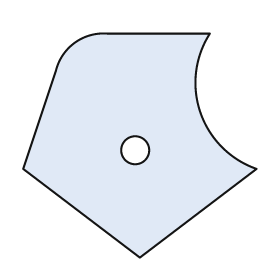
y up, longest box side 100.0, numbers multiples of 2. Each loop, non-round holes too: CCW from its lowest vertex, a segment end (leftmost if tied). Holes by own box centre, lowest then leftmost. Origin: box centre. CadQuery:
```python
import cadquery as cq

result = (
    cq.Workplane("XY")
    .moveTo(0.0, -48.0)
    .lineTo(50.0, -10.0)
    .threePointArc((26.0, 14.0), (30.0, 48.0))
    .lineTo(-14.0, 48.0)
    .threePointArc((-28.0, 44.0), (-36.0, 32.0))
    .lineTo(-50.0, -10.0)
    .close()
    .moveTo(-2.0, -2.0)
    .circle(6.0)
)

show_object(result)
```